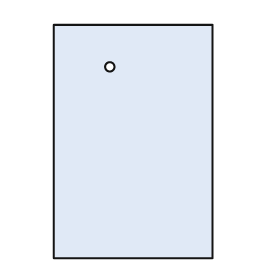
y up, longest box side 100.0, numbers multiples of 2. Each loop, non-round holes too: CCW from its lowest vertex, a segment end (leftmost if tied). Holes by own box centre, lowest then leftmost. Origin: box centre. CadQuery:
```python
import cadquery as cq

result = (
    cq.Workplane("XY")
    .moveTo(-34.0, -50.0)
    .lineTo(34.0, -50.0)
    .lineTo(34.0, 50.0)
    .lineTo(-34.0, 50.0)
    .close()
    .moveTo(-10.0, 32.0)
    .circle(2.0)
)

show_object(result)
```